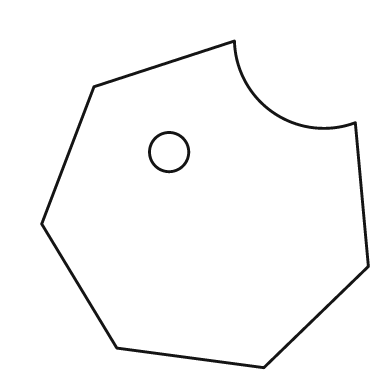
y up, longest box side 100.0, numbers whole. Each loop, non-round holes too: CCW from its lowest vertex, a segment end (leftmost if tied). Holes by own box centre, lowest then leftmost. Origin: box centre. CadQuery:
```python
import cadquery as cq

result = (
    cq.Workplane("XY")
    .moveTo(18.0, -50.0)
    .lineTo(50.0, -19.0)
    .lineTo(46.0, 25.0)
    .threePointArc((21.0, 28.0), (9.0, 50.0))
    .lineTo(-34.0, 36.0)
    .lineTo(-50.0, -6.0)
    .lineTo(-27.0, -44.0)
    .close()
    .moveTo(-11.0, 16.0)
    .circle(6.0)
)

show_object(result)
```